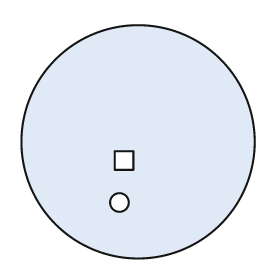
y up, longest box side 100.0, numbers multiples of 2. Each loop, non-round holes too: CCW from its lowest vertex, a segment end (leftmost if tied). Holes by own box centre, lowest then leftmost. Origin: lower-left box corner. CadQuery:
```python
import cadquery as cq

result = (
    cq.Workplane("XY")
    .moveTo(50.0, 50.0)
    .circle(50.0)
    .moveTo(42.0, 24.0)
    .circle(4.0)
    .moveTo(40.0, 38.0)
    .lineTo(48.0, 38.0)
    .lineTo(48.0, 46.0)
    .lineTo(40.0, 46.0)
    .close()
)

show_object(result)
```